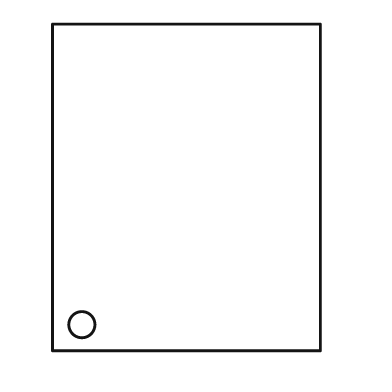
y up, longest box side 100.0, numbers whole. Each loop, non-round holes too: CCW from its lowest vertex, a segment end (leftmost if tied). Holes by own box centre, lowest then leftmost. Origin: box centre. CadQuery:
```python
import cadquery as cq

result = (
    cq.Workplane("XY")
    .moveTo(-41.0, -50.0)
    .lineTo(41.0, -50.0)
    .lineTo(41.0, 50.0)
    .lineTo(-41.0, 50.0)
    .close()
    .moveTo(-32.0, -42.0)
    .circle(4.0)
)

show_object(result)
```